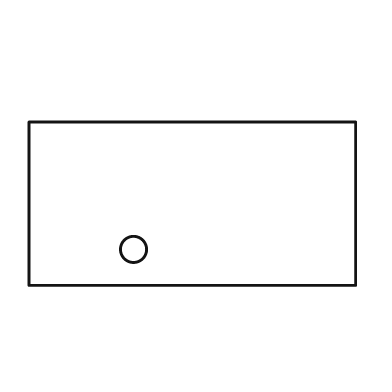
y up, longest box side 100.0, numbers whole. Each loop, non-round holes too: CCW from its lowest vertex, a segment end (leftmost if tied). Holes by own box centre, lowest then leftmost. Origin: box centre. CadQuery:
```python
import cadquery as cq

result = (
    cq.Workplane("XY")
    .moveTo(-50.0, -25.0)
    .lineTo(50.0, -25.0)
    .lineTo(50.0, 25.0)
    .lineTo(-50.0, 25.0)
    .close()
    .moveTo(-18.0, -14.0)
    .circle(4.0)
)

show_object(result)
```